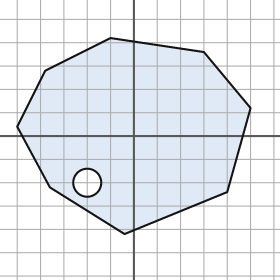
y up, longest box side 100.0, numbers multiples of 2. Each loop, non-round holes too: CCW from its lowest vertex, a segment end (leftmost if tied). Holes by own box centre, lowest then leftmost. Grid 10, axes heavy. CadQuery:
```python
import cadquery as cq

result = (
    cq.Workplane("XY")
    .moveTo(-4.0, -42.0)
    .lineTo(40.0, -24.0)
    .lineTo(50.0, 12.0)
    .lineTo(30.0, 36.0)
    .lineTo(-10.0, 42.0)
    .lineTo(-38.0, 28.0)
    .lineTo(-50.0, 4.0)
    .lineTo(-36.0, -22.0)
    .close()
    .moveTo(-20.0, -20.0)
    .circle(6.0)
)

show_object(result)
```